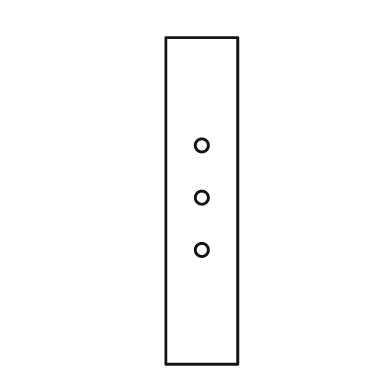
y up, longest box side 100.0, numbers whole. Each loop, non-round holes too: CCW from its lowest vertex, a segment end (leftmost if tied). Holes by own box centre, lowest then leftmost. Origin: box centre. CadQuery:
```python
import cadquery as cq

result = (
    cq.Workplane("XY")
    .moveTo(-11.0, -50.0)
    .lineTo(11.0, -50.0)
    .lineTo(11.0, 50.0)
    .lineTo(-11.0, 50.0)
    .close()
    .moveTo(0.0, -15.0)
    .circle(2.0)
    .moveTo(0.0, 1.0)
    .circle(2.0)
    .moveTo(0.0, 17.0)
    .circle(2.0)
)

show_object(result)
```